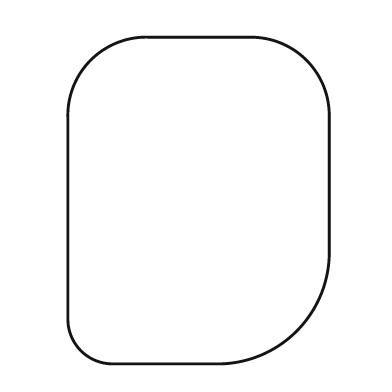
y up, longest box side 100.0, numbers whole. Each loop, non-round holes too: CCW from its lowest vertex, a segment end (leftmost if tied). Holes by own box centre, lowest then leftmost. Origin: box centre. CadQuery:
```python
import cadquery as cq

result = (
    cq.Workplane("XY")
    .moveTo(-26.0, -50.0)
    .lineTo(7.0, -50.0)
    .threePointArc((30.0, -40.0), (40.0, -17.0))
    .lineTo(40.0, 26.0)
    .threePointArc((33.0, 43.0), (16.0, 50.0))
    .lineTo(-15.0, 50.0)
    .threePointArc((-33.0, 43.0), (-40.0, 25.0))
    .lineTo(-40.0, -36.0)
    .threePointArc((-36.0, -46.0), (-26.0, -50.0))
    .close()
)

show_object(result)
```